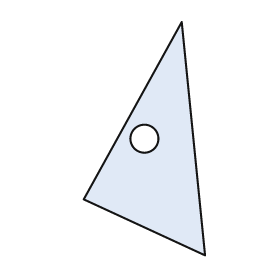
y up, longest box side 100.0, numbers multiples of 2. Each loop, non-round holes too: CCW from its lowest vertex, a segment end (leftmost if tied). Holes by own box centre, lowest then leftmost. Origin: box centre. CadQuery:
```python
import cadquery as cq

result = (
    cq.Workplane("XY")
    .moveTo(26.0, -50.0)
    .lineTo(16.0, 50.0)
    .lineTo(-26.0, -26.0)
    .close()
    .moveTo(0.0, 0.0)
    .circle(6.0)
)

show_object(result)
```